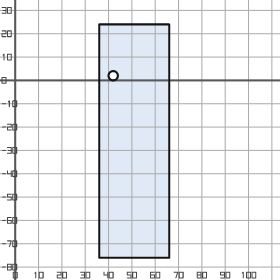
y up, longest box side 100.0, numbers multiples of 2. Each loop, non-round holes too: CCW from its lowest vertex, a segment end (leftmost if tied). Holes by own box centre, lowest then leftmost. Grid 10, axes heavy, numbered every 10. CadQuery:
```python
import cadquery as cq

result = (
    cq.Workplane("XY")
    .moveTo(36.0, -76.0)
    .lineTo(66.0, -76.0)
    .lineTo(66.0, 24.0)
    .lineTo(36.0, 24.0)
    .close()
    .moveTo(42.0, 2.0)
    .circle(2.0)
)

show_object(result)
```